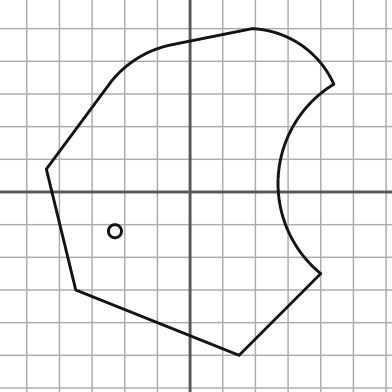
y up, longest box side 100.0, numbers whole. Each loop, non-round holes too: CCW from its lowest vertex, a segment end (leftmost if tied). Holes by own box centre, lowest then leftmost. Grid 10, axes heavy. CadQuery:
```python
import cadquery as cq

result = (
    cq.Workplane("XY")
    .moveTo(15.0, -50.0)
    .lineTo(40.0, -25.0)
    .threePointArc((27.0, 5.0), (44.0, 33.0))
    .threePointArc((34.0, 45.0), (19.0, 50.0))
    .lineTo(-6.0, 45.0)
    .threePointArc((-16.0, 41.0), (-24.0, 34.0))
    .lineTo(-44.0, 7.0)
    .lineTo(-35.0, -30.0)
    .close()
    .moveTo(-23.0, -12.0)
    .circle(2.0)
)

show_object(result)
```